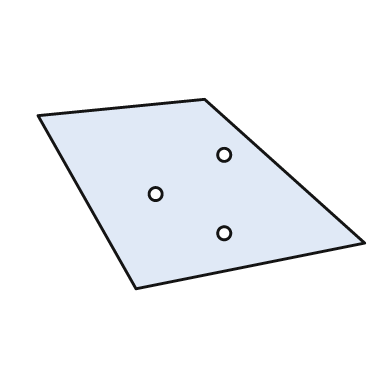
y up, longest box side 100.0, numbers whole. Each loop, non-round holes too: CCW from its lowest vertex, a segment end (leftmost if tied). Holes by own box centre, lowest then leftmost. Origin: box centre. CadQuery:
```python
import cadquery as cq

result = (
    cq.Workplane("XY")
    .moveTo(-20.0, -29.0)
    .lineTo(50.0, -15.0)
    .lineTo(1.0, 29.0)
    .lineTo(-50.0, 24.0)
    .close()
    .moveTo(7.0, -12.0)
    .circle(2.0)
    .moveTo(-14.0, 0.0)
    .circle(2.0)
    .moveTo(7.0, 12.0)
    .circle(2.0)
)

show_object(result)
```